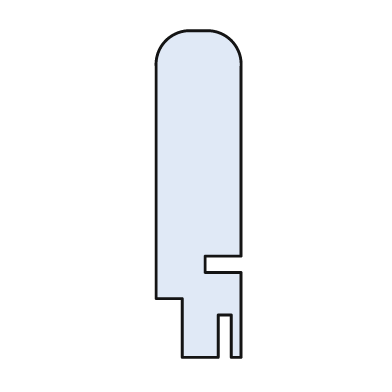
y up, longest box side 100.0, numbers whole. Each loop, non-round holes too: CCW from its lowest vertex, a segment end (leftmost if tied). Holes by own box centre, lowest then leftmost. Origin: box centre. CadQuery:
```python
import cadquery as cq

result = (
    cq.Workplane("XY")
    .moveTo(-5.0, -50.0)
    .lineTo(6.0, -50.0)
    .lineTo(6.0, -37.0)
    .lineTo(10.0, -37.0)
    .lineTo(10.0, -50.0)
    .lineTo(13.0, -50.0)
    .lineTo(13.0, -24.0)
    .lineTo(2.0, -24.0)
    .lineTo(2.0, -19.0)
    .lineTo(13.0, -19.0)
    .lineTo(13.0, 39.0)
    .threePointArc((10.0, 47.0), (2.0, 50.0))
    .lineTo(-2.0, 50.0)
    .threePointArc((-10.0, 47.0), (-13.0, 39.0))
    .lineTo(-13.0, -32.0)
    .lineTo(-5.0, -32.0)
    .close()
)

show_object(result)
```